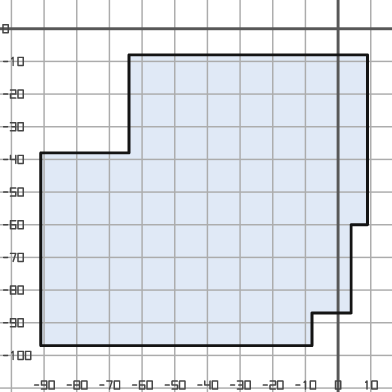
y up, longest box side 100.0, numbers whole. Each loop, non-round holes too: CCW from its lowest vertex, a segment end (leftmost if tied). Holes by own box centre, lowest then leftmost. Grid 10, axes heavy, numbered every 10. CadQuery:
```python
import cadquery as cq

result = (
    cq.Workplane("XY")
    .moveTo(-91.0, -97.0)
    .lineTo(-8.0, -97.0)
    .lineTo(-8.0, -87.0)
    .lineTo(4.0, -87.0)
    .lineTo(4.0, -60.0)
    .lineTo(9.0, -60.0)
    .lineTo(9.0, -8.0)
    .lineTo(-64.0, -8.0)
    .lineTo(-64.0, -38.0)
    .lineTo(-91.0, -38.0)
    .close()
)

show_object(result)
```